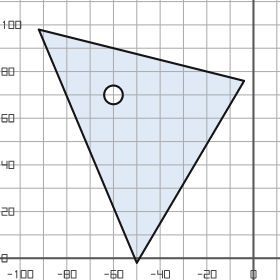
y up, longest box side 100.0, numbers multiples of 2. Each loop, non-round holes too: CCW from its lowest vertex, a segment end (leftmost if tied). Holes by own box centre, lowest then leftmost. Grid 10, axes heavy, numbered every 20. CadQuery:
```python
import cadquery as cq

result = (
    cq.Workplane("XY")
    .moveTo(-50.0, -2.0)
    .lineTo(-4.0, 76.0)
    .lineTo(-92.0, 98.0)
    .close()
    .moveTo(-60.0, 70.0)
    .circle(4.0)
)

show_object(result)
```